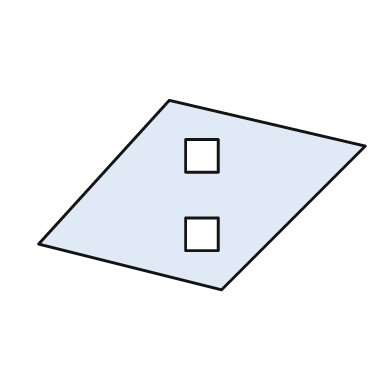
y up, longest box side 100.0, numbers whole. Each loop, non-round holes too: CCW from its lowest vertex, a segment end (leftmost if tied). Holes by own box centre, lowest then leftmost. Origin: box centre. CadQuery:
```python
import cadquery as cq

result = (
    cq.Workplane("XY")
    .moveTo(6.0, -29.0)
    .lineTo(50.0, 15.0)
    .lineTo(-10.0, 29.0)
    .lineTo(-50.0, -15.0)
    .close()
    .moveTo(-5.0, -17.0)
    .lineTo(5.0, -17.0)
    .lineTo(5.0, -7.0)
    .lineTo(-5.0, -7.0)
    .close()
    .moveTo(-5.0, 7.0)
    .lineTo(5.0, 7.0)
    .lineTo(5.0, 17.0)
    .lineTo(-5.0, 17.0)
    .close()
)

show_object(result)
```